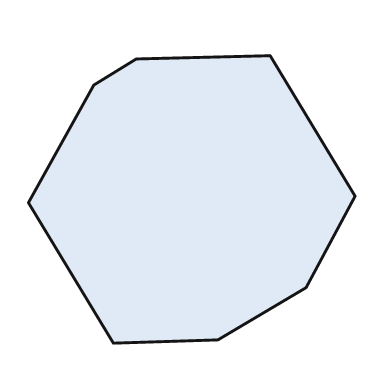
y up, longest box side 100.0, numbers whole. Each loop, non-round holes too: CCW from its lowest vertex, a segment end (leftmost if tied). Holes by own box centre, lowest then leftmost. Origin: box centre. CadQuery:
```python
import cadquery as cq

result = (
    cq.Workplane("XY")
    .moveTo(-24.0, -44.0)
    .lineTo(8.0, -43.0)
    .lineTo(35.0, -27.0)
    .lineTo(50.0, 1.0)
    .lineTo(24.0, 44.0)
    .lineTo(-17.0, 43.0)
    .lineTo(-30.0, 35.0)
    .lineTo(-50.0, -1.0)
    .close()
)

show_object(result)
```